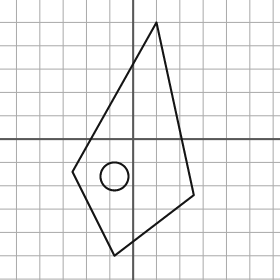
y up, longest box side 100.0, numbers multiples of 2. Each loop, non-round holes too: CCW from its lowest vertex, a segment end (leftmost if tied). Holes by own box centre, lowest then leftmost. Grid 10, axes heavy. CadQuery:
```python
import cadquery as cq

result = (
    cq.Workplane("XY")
    .moveTo(-8.0, -50.0)
    .lineTo(26.0, -24.0)
    .lineTo(10.0, 50.0)
    .lineTo(-26.0, -14.0)
    .close()
    .moveTo(-8.0, -16.0)
    .circle(6.0)
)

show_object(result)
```